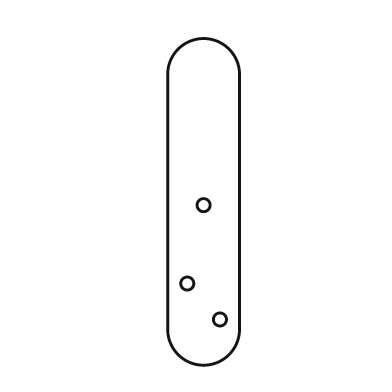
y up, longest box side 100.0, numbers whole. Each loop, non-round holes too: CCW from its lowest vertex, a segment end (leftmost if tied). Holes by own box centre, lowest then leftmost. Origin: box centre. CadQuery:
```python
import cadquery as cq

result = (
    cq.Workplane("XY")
    .moveTo(-11.0, -39.0)
    .threePointArc((0.0, -50.0), (11.0, -39.0))
    .lineTo(11.0, 39.0)
    .threePointArc((0.0, 50.0), (-11.0, 39.0))
    .close()
    .moveTo(5.0, -36.0)
    .circle(2.0)
    .moveTo(-5.0, -25.0)
    .circle(2.0)
    .moveTo(0.0, -1.0)
    .circle(2.0)
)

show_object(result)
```